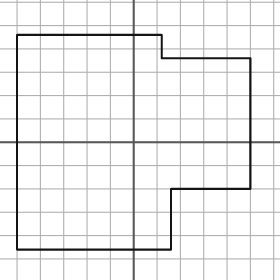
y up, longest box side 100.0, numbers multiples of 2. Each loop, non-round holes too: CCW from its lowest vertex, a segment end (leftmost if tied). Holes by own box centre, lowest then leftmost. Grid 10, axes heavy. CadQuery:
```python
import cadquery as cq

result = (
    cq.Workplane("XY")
    .moveTo(-50.0, -46.0)
    .lineTo(16.0, -46.0)
    .lineTo(16.0, -20.0)
    .lineTo(50.0, -20.0)
    .lineTo(50.0, 36.0)
    .lineTo(12.0, 36.0)
    .lineTo(12.0, 46.0)
    .lineTo(-50.0, 46.0)
    .close()
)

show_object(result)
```